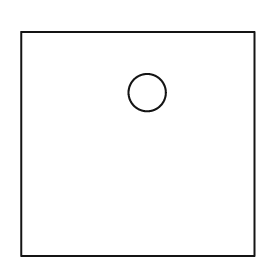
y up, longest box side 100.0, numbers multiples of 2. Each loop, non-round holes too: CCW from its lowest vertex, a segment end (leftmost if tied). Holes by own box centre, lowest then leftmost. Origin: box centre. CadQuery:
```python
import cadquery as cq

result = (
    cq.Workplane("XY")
    .moveTo(-50.0, -48.0)
    .lineTo(50.0, -48.0)
    .lineTo(50.0, 48.0)
    .lineTo(-50.0, 48.0)
    .close()
    .moveTo(4.0, 22.0)
    .circle(8.0)
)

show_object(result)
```